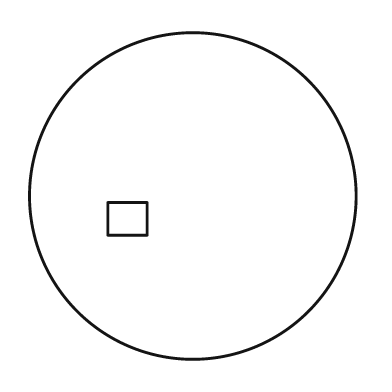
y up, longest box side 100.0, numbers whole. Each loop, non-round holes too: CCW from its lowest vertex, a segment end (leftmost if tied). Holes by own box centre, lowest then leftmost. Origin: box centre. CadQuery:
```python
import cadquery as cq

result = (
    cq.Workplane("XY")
    .moveTo(0.0, 0.0)
    .circle(50.0)
    .moveTo(-26.0, -12.0)
    .lineTo(-14.0, -12.0)
    .lineTo(-14.0, -2.0)
    .lineTo(-26.0, -2.0)
    .close()
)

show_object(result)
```